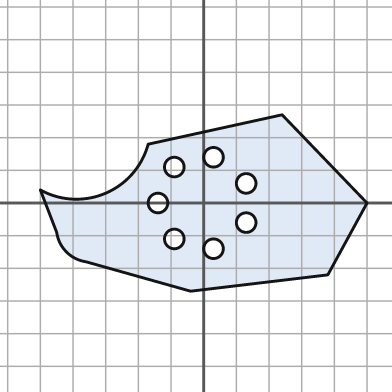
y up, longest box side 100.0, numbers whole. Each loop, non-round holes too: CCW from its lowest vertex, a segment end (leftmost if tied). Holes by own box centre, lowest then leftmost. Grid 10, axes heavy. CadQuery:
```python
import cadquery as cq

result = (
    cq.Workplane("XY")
    .moveTo(-4.0, -27.0)
    .lineTo(38.0, -22.0)
    .lineTo(50.0, 0.0)
    .lineTo(24.0, 27.0)
    .lineTo(-17.0, 18.0)
    .threePointArc((-30.0, 3.0), (-50.0, 4.0))
    .lineTo(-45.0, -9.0)
    .threePointArc((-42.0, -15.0), (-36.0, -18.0))
    .close()
    .moveTo(3.0, -14.0)
    .circle(3.0)
    .moveTo(-9.0, -11.0)
    .circle(3.0)
    .moveTo(13.0, -6.0)
    .circle(3.0)
    .moveTo(-14.0, 0.0)
    .circle(3.0)
    .moveTo(13.0, 6.0)
    .circle(3.0)
    .moveTo(-9.0, 11.0)
    .circle(3.0)
    .moveTo(3.0, 14.0)
    .circle(3.0)
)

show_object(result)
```